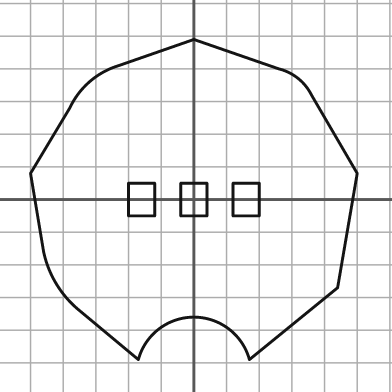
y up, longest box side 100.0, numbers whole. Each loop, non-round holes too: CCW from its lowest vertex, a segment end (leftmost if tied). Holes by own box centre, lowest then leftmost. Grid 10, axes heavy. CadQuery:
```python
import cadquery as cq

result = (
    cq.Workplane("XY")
    .moveTo(-17.0, -49.0)
    .threePointArc((0.0, -36.0), (17.0, -49.0))
    .lineTo(44.0, -27.0)
    .lineTo(50.0, 8.0)
    .lineTo(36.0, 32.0)
    .threePointArc((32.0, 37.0), (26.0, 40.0))
    .lineTo(0.0, 49.0)
    .lineTo(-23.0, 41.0)
    .threePointArc((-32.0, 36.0), (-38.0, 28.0))
    .lineTo(-50.0, 8.0)
    .lineTo(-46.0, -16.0)
    .threePointArc((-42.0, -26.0), (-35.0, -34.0))
    .close()
    .moveTo(-20.0, -5.0)
    .lineTo(-12.0, -5.0)
    .lineTo(-12.0, 5.0)
    .lineTo(-20.0, 5.0)
    .close()
    .moveTo(-4.0, -5.0)
    .lineTo(4.0, -5.0)
    .lineTo(4.0, 5.0)
    .lineTo(-4.0, 5.0)
    .close()
    .moveTo(12.0, -5.0)
    .lineTo(20.0, -5.0)
    .lineTo(20.0, 5.0)
    .lineTo(12.0, 5.0)
    .close()
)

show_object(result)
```